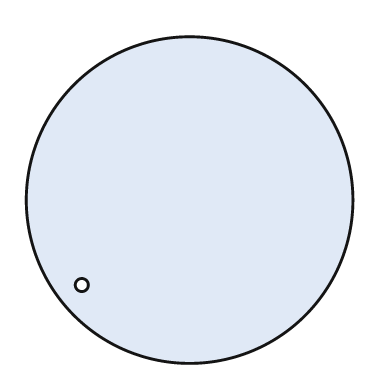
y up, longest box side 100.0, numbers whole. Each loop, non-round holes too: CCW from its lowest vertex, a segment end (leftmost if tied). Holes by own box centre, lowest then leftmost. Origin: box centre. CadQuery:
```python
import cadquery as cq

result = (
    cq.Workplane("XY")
    .moveTo(0.0, 0.0)
    .circle(50.0)
    .moveTo(-33.0, -26.0)
    .circle(2.0)
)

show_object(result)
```